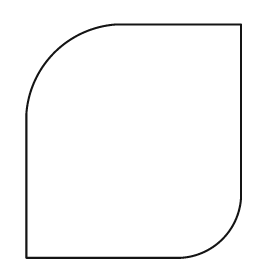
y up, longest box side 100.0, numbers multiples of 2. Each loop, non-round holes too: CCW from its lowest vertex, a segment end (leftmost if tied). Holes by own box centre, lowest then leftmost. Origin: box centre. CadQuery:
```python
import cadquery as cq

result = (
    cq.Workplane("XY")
    .moveTo(-46.0, -50.0)
    .lineTo(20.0, -50.0)
    .threePointArc((38.0, -42.0), (46.0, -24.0))
    .lineTo(46.0, 50.0)
    .lineTo(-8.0, 50.0)
    .threePointArc((-34.0, 38.0), (-46.0, 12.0))
    .close()
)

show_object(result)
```